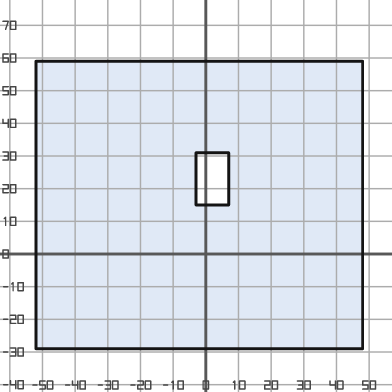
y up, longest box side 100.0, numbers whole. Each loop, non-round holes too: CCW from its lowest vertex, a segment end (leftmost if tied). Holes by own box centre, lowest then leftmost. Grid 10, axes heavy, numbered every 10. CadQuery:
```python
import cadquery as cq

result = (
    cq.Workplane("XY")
    .moveTo(-52.0, -29.0)
    .lineTo(48.0, -29.0)
    .lineTo(48.0, 59.0)
    .lineTo(-52.0, 59.0)
    .close()
    .moveTo(-3.0, 15.0)
    .lineTo(7.0, 15.0)
    .lineTo(7.0, 31.0)
    .lineTo(-3.0, 31.0)
    .close()
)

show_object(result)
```